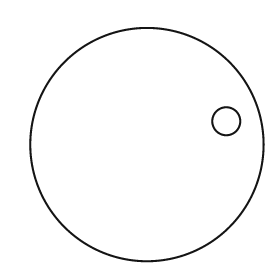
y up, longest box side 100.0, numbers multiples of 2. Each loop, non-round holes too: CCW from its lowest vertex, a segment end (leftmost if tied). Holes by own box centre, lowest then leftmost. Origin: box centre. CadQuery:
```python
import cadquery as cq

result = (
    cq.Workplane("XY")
    .moveTo(0.0, 0.0)
    .circle(50.0)
    .moveTo(34.0, 10.0)
    .circle(6.0)
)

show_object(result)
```